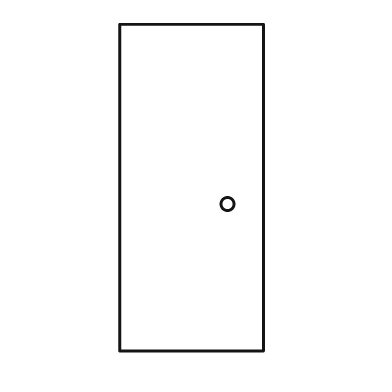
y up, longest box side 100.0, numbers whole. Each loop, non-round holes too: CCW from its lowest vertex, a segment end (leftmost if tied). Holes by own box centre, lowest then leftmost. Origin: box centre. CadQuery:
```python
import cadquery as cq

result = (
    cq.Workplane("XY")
    .moveTo(-22.0, -50.0)
    .lineTo(22.0, -50.0)
    .lineTo(22.0, 50.0)
    .lineTo(-22.0, 50.0)
    .close()
    .moveTo(11.0, -5.0)
    .circle(2.0)
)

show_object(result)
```